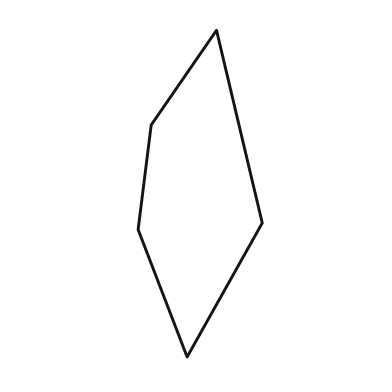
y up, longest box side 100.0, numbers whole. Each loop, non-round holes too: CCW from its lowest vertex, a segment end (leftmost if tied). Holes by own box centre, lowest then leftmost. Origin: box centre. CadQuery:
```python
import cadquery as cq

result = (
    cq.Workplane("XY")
    .moveTo(-4.0, -50.0)
    .lineTo(19.0, -9.0)
    .lineTo(5.0, 50.0)
    .lineTo(-15.0, 21.0)
    .lineTo(-19.0, -11.0)
    .close()
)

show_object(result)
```